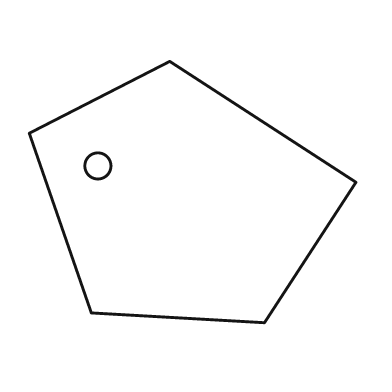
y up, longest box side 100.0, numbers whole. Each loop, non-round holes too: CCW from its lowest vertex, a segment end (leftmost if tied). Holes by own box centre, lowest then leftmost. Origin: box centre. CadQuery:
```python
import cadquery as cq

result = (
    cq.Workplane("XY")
    .moveTo(22.0, -40.0)
    .lineTo(50.0, 3.0)
    .lineTo(-7.0, 40.0)
    .lineTo(-50.0, 18.0)
    .lineTo(-31.0, -37.0)
    .close()
    .moveTo(-29.0, 8.0)
    .circle(4.0)
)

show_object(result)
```